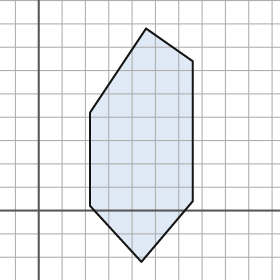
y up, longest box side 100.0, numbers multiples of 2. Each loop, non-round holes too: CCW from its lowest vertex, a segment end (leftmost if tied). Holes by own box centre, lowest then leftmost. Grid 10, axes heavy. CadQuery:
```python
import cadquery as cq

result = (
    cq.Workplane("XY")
    .moveTo(44.0, -22.0)
    .lineTo(66.0, 4.0)
    .lineTo(66.0, 64.0)
    .lineTo(46.0, 78.0)
    .lineTo(22.0, 42.0)
    .lineTo(22.0, 2.0)
    .close()
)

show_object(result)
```